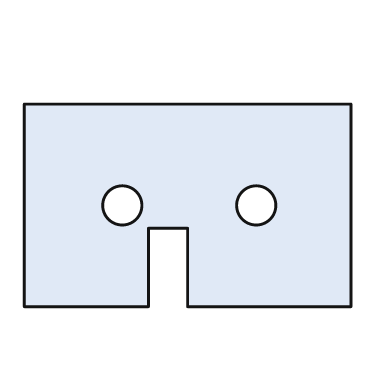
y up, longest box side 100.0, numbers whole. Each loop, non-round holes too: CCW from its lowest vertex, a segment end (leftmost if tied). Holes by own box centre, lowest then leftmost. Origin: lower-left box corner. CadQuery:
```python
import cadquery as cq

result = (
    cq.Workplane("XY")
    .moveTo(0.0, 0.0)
    .lineTo(38.0, 0.0)
    .lineTo(38.0, 24.0)
    .lineTo(50.0, 24.0)
    .lineTo(50.0, 0.0)
    .lineTo(100.0, 0.0)
    .lineTo(100.0, 62.0)
    .lineTo(0.0, 62.0)
    .close()
    .moveTo(30.0, 31.0)
    .circle(6.0)
    .moveTo(71.0, 31.0)
    .circle(6.0)
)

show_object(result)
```